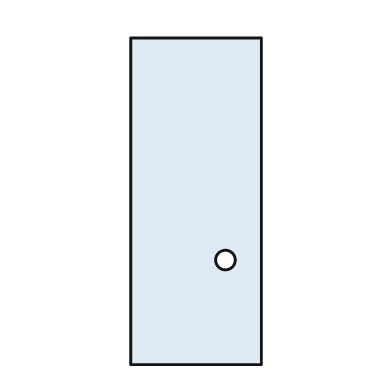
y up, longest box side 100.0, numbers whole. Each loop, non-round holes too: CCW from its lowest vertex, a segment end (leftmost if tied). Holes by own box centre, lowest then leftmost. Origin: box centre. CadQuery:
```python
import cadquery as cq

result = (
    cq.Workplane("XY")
    .moveTo(-20.0, -50.0)
    .lineTo(20.0, -50.0)
    .lineTo(20.0, 50.0)
    .lineTo(-20.0, 50.0)
    .close()
    .moveTo(9.0, -18.0)
    .circle(3.0)
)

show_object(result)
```